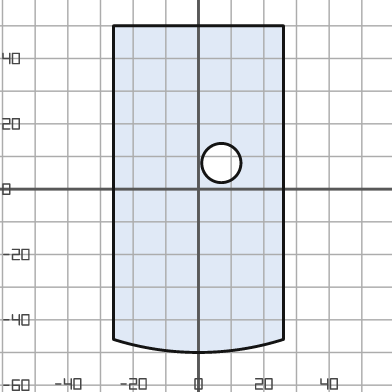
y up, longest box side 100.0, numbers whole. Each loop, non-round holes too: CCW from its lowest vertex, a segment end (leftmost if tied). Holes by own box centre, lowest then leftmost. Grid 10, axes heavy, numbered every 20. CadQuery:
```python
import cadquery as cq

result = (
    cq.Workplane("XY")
    .moveTo(-26.0, -46.0)
    .threePointArc((0.0, -50.0), (26.0, -46.0))
    .lineTo(26.0, 50.0)
    .lineTo(-26.0, 50.0)
    .close()
    .moveTo(7.0, 8.0)
    .circle(6.0)
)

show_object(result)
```